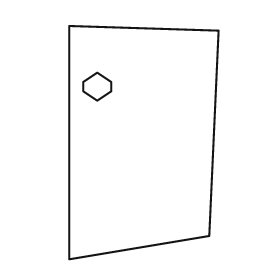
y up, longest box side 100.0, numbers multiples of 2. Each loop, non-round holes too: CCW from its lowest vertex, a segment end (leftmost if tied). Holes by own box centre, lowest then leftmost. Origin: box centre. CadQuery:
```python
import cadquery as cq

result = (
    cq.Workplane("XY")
    .moveTo(-32.0, -50.0)
    .lineTo(28.0, -40.0)
    .lineTo(32.0, 48.0)
    .lineTo(-32.0, 50.0)
    .close()
    .moveTo(-20.0, 18.0)
    .lineTo(-14.0, 22.0)
    .lineTo(-14.0, 26.0)
    .lineTo(-20.0, 30.0)
    .lineTo(-26.0, 26.0)
    .lineTo(-26.0, 22.0)
    .close()
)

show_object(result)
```